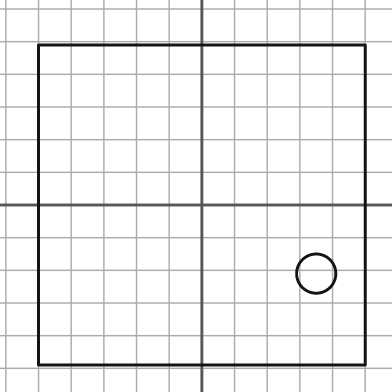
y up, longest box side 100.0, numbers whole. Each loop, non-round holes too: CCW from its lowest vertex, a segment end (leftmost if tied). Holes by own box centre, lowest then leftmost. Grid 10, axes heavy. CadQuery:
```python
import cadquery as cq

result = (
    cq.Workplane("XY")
    .moveTo(-50.0, -49.0)
    .lineTo(50.0, -49.0)
    .lineTo(50.0, 49.0)
    .lineTo(-50.0, 49.0)
    .close()
    .moveTo(35.0, -21.0)
    .circle(6.0)
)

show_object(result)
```